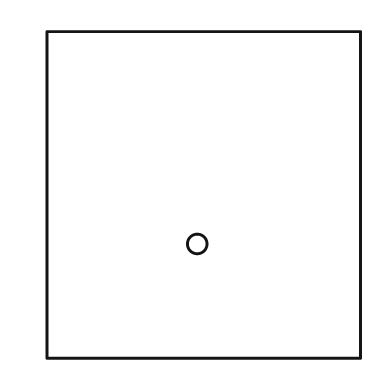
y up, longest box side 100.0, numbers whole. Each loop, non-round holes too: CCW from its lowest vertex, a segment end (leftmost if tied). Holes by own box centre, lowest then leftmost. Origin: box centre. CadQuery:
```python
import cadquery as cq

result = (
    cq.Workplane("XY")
    .moveTo(-48.0, -50.0)
    .lineTo(48.0, -50.0)
    .lineTo(48.0, 50.0)
    .lineTo(-48.0, 50.0)
    .close()
    .moveTo(-2.0, -15.0)
    .circle(3.0)
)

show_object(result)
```